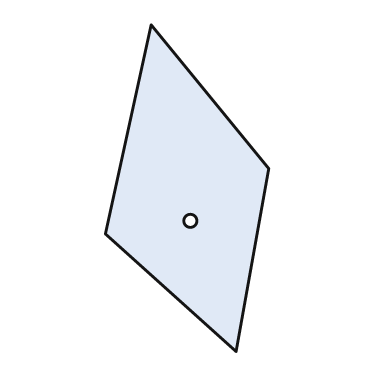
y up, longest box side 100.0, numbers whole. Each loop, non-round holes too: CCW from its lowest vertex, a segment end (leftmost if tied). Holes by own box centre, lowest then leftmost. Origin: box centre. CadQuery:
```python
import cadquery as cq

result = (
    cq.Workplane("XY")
    .moveTo(15.0, -50.0)
    .lineTo(25.0, 6.0)
    .lineTo(-11.0, 50.0)
    .lineTo(-25.0, -14.0)
    .close()
    .moveTo(1.0, -10.0)
    .circle(2.0)
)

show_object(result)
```